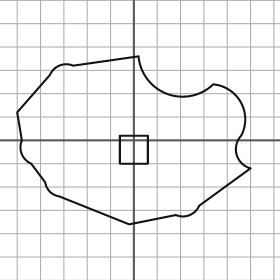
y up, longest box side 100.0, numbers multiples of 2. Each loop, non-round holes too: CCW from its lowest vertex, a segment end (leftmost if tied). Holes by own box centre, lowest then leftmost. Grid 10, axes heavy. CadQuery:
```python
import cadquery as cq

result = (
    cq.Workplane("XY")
    .moveTo(-2.0, -36.0)
    .lineTo(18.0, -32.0)
    .threePointArc((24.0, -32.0), (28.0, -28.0))
    .lineTo(50.0, -12.0)
    .threePointArc((44.0, -6.0), (46.0, 2.0))
    .threePointArc((46.0, 16.0), (34.0, 24.0))
    .threePointArc((14.0, 20.0), (2.0, 36.0))
    .lineTo(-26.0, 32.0)
    .threePointArc((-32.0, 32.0), (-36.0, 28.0))
    .lineTo(-50.0, 12.0)
    .lineTo(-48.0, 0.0)
    .threePointArc((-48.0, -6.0), (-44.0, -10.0))
    .lineTo(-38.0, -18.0)
    .threePointArc((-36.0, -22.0), (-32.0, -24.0))
    .close()
    .moveTo(-6.0, -10.0)
    .lineTo(6.0, -10.0)
    .lineTo(6.0, 2.0)
    .lineTo(-6.0, 2.0)
    .close()
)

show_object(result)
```